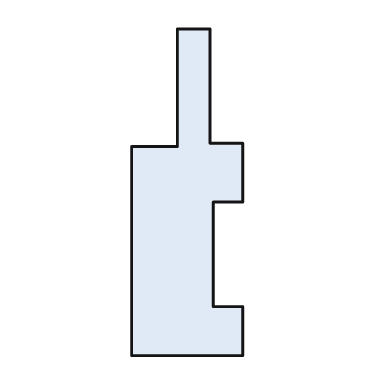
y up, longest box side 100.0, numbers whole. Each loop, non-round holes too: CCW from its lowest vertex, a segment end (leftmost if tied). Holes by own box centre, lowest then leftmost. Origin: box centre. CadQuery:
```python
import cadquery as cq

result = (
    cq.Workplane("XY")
    .moveTo(-17.0, -50.0)
    .lineTo(17.0, -50.0)
    .lineTo(17.0, -35.0)
    .lineTo(8.0, -35.0)
    .lineTo(8.0, -3.0)
    .lineTo(17.0, -3.0)
    .lineTo(17.0, 15.0)
    .lineTo(7.0, 15.0)
    .lineTo(7.0, 50.0)
    .lineTo(-3.0, 50.0)
    .lineTo(-3.0, 14.0)
    .lineTo(-17.0, 14.0)
    .close()
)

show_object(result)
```